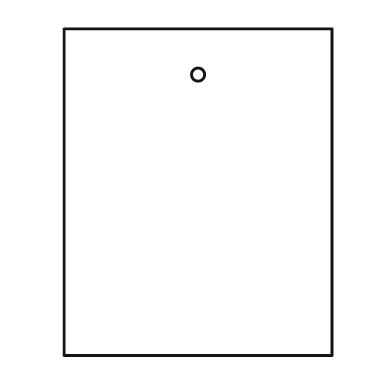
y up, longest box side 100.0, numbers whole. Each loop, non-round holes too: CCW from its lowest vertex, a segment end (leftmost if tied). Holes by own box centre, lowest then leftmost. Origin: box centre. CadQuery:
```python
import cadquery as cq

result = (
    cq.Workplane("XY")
    .moveTo(-41.0, -50.0)
    .lineTo(41.0, -50.0)
    .lineTo(41.0, 50.0)
    .lineTo(-41.0, 50.0)
    .close()
    .moveTo(0.0, 36.0)
    .circle(2.0)
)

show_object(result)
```